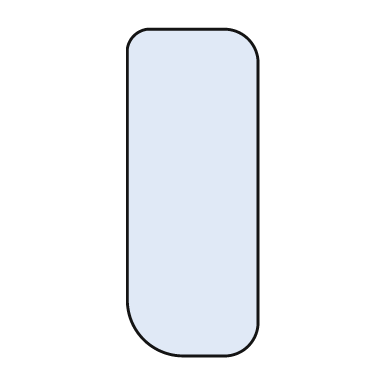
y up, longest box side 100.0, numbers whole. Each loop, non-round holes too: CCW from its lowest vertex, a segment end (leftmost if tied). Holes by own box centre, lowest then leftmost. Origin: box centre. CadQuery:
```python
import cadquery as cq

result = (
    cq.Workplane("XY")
    .moveTo(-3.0, -50.0)
    .lineTo(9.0, -50.0)
    .threePointArc((17.0, -47.0), (20.0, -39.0))
    .lineTo(20.0, 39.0)
    .threePointArc((17.0, 47.0), (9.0, 50.0))
    .lineTo(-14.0, 50.0)
    .threePointArc((-18.0, 48.0), (-20.0, 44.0))
    .lineTo(-20.0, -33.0)
    .threePointArc((-15.0, -45.0), (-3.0, -50.0))
    .close()
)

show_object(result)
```